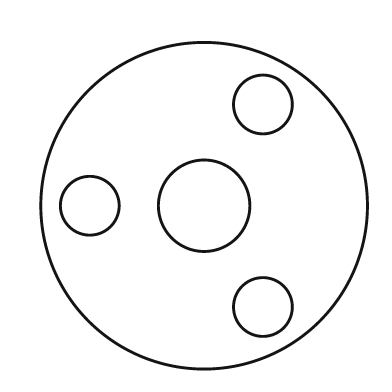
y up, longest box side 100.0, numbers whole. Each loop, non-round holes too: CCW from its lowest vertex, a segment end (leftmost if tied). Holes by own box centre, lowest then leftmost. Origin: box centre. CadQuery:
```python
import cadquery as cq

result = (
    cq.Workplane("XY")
    .moveTo(0.0, 0.0)
    .circle(50.0)
    .moveTo(18.0, -31.0)
    .circle(9.0)
    .moveTo(-35.0, 0.0)
    .circle(9.0)
    .moveTo(0.0, 0.0)
    .circle(14.0)
    .moveTo(18.0, 31.0)
    .circle(9.0)
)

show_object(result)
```